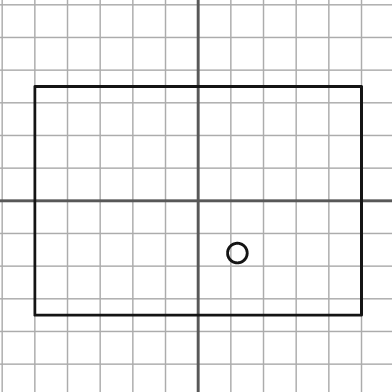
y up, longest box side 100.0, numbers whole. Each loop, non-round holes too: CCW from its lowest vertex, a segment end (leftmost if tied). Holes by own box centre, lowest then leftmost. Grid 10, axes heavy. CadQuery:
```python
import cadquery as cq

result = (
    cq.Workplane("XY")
    .moveTo(-50.0, -35.0)
    .lineTo(50.0, -35.0)
    .lineTo(50.0, 35.0)
    .lineTo(-50.0, 35.0)
    .close()
    .moveTo(12.0, -16.0)
    .circle(3.0)
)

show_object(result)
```